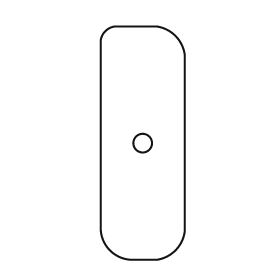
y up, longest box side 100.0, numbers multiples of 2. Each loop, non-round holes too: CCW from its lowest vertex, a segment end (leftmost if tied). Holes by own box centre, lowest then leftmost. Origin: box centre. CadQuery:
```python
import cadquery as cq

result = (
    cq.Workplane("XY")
    .moveTo(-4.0, -50.0)
    .lineTo(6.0, -50.0)
    .threePointArc((14.0, -46.0), (18.0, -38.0))
    .lineTo(18.0, 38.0)
    .threePointArc((14.0, 46.0), (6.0, 50.0))
    .lineTo(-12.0, 50.0)
    .threePointArc((-16.0, 48.0), (-18.0, 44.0))
    .lineTo(-18.0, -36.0)
    .threePointArc((-14.0, -46.0), (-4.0, -50.0))
    .close()
    .moveTo(0.0, 0.0)
    .circle(4.0)
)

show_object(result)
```